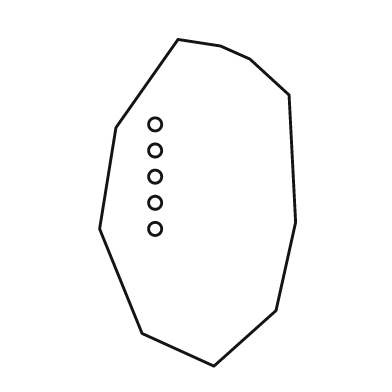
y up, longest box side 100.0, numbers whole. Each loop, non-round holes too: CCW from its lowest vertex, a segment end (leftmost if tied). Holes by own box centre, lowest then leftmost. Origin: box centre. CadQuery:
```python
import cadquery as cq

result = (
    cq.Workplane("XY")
    .moveTo(5.0, -50.0)
    .lineTo(24.0, -33.0)
    .lineTo(30.0, -6.0)
    .lineTo(28.0, 33.0)
    .lineTo(16.0, 44.0)
    .lineTo(7.0, 48.0)
    .lineTo(-6.0, 50.0)
    .lineTo(-25.0, 23.0)
    .lineTo(-30.0, -8.0)
    .lineTo(-17.0, -40.0)
    .close()
    .moveTo(-13.0, -8.0)
    .circle(2.0)
    .moveTo(-13.0, 0.0)
    .circle(2.0)
    .moveTo(-13.0, 8.0)
    .circle(2.0)
    .moveTo(-13.0, 16.0)
    .circle(2.0)
    .moveTo(-13.0, 24.0)
    .circle(2.0)
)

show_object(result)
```